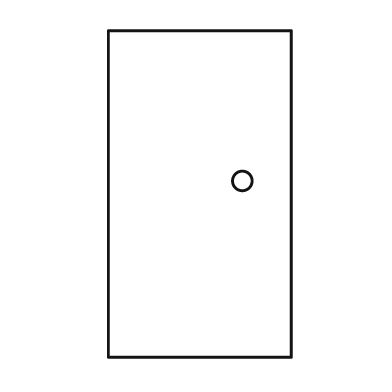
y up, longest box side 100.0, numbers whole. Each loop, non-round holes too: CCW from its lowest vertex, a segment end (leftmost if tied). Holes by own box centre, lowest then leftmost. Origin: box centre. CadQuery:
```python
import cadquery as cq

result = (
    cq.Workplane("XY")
    .moveTo(-28.0, -50.0)
    .lineTo(28.0, -50.0)
    .lineTo(28.0, 50.0)
    .lineTo(-28.0, 50.0)
    .close()
    .moveTo(13.0, 4.0)
    .circle(3.0)
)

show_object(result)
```